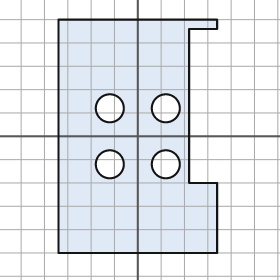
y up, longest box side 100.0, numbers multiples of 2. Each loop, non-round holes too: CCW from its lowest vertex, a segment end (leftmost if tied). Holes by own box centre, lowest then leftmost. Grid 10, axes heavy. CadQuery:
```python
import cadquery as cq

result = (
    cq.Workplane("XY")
    .moveTo(-34.0, -50.0)
    .lineTo(34.0, -50.0)
    .lineTo(34.0, -20.0)
    .lineTo(22.0, -20.0)
    .lineTo(22.0, 46.0)
    .lineTo(34.0, 46.0)
    .lineTo(34.0, 50.0)
    .lineTo(-34.0, 50.0)
    .close()
    .moveTo(-12.0, -12.0)
    .circle(6.0)
    .moveTo(12.0, -12.0)
    .circle(6.0)
    .moveTo(-12.0, 12.0)
    .circle(6.0)
    .moveTo(12.0, 12.0)
    .circle(6.0)
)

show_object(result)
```